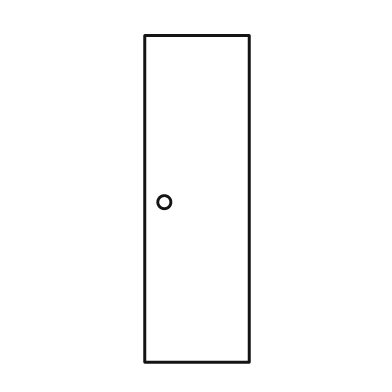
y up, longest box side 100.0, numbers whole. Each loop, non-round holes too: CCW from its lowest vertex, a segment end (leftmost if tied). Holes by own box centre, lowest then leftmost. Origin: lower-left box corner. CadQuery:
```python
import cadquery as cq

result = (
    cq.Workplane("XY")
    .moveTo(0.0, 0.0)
    .lineTo(32.0, 0.0)
    .lineTo(32.0, 100.0)
    .lineTo(0.0, 100.0)
    .close()
    .moveTo(6.0, 49.0)
    .circle(2.0)
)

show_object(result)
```